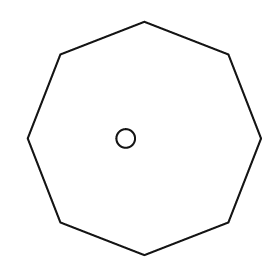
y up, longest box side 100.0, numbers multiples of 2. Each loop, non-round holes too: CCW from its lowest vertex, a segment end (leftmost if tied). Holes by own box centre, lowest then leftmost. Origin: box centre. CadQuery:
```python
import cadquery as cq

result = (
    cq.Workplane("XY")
    .moveTo(0.0, -50.0)
    .lineTo(36.0, -36.0)
    .lineTo(50.0, 0.0)
    .lineTo(36.0, 36.0)
    .lineTo(0.0, 50.0)
    .lineTo(-36.0, 36.0)
    .lineTo(-50.0, 0.0)
    .lineTo(-36.0, -36.0)
    .close()
    .moveTo(-8.0, 0.0)
    .circle(4.0)
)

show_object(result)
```